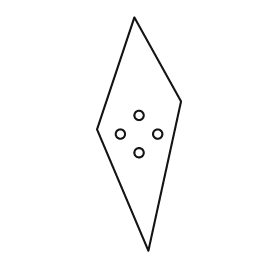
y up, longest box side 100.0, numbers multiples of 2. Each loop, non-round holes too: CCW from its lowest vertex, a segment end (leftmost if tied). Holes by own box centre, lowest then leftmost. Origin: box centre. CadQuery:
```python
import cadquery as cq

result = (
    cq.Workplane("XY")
    .moveTo(4.0, -50.0)
    .lineTo(18.0, 14.0)
    .lineTo(-2.0, 50.0)
    .lineTo(-18.0, 2.0)
    .close()
    .moveTo(0.0, -8.0)
    .circle(2.0)
    .moveTo(-8.0, 0.0)
    .circle(2.0)
    .moveTo(8.0, 0.0)
    .circle(2.0)
    .moveTo(0.0, 8.0)
    .circle(2.0)
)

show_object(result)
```